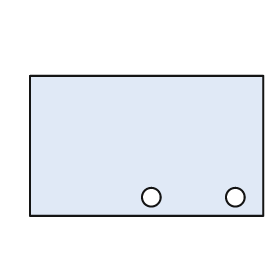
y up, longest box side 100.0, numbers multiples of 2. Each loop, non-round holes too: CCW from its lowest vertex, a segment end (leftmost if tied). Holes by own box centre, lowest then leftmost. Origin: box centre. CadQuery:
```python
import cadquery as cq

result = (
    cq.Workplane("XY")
    .moveTo(-50.0, -30.0)
    .lineTo(50.0, -30.0)
    .lineTo(50.0, 30.0)
    .lineTo(-50.0, 30.0)
    .close()
    .moveTo(2.0, -22.0)
    .circle(4.0)
    .moveTo(38.0, -22.0)
    .circle(4.0)
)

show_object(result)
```